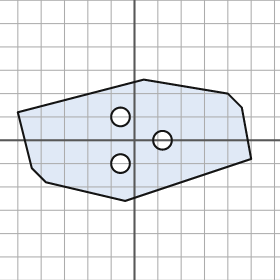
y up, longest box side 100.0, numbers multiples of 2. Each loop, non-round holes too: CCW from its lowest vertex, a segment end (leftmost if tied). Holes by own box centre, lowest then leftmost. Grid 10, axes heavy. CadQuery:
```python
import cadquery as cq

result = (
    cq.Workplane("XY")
    .moveTo(-4.0, -26.0)
    .lineTo(50.0, -8.0)
    .lineTo(46.0, 14.0)
    .lineTo(40.0, 20.0)
    .lineTo(4.0, 26.0)
    .lineTo(-50.0, 12.0)
    .lineTo(-44.0, -12.0)
    .lineTo(-38.0, -18.0)
    .close()
    .moveTo(-6.0, -10.0)
    .circle(4.0)
    .moveTo(12.0, 0.0)
    .circle(4.0)
    .moveTo(-6.0, 10.0)
    .circle(4.0)
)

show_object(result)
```